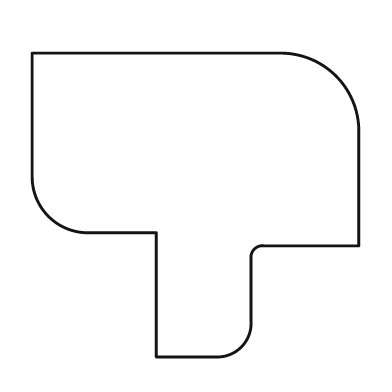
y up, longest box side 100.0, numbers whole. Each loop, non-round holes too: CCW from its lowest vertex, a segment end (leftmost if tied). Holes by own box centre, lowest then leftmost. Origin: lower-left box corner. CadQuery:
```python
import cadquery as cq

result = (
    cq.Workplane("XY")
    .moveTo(38.0, 0.0)
    .lineTo(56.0, 0.0)
    .threePointArc((64.0, 3.0), (67.0, 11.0))
    .lineTo(67.0, 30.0)
    .threePointArc((68.0, 33.0), (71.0, 34.0))
    .lineTo(100.0, 34.0)
    .lineTo(100.0, 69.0)
    .threePointArc((93.0, 86.0), (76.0, 93.0))
    .lineTo(0.0, 93.0)
    .lineTo(0.0, 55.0)
    .threePointArc((5.0, 43.0), (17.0, 38.0))
    .lineTo(38.0, 38.0)
    .close()
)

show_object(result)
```